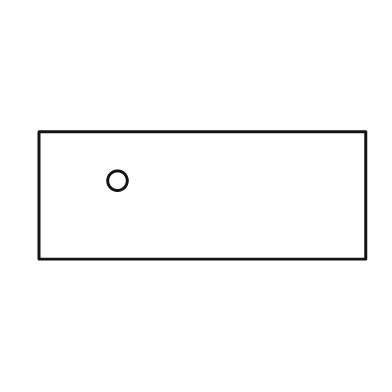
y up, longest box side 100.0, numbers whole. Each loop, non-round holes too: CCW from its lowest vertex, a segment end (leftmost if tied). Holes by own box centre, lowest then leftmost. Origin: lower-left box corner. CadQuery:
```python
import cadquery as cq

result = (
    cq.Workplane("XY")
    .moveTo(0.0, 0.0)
    .lineTo(100.0, 0.0)
    .lineTo(100.0, 39.0)
    .lineTo(0.0, 39.0)
    .close()
    .moveTo(24.0, 24.0)
    .circle(3.0)
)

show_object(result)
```